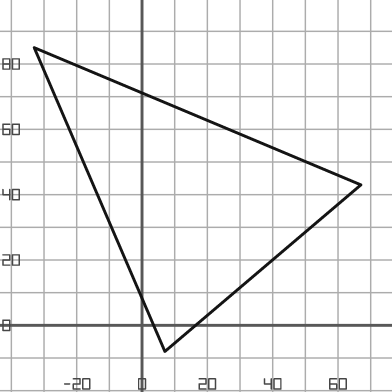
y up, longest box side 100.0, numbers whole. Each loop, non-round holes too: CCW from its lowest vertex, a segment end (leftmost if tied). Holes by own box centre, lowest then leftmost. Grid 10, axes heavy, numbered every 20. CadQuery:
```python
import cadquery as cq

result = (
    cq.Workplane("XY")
    .moveTo(7.0, -8.0)
    .lineTo(67.0, 43.0)
    .lineTo(-33.0, 85.0)
    .close()
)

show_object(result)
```